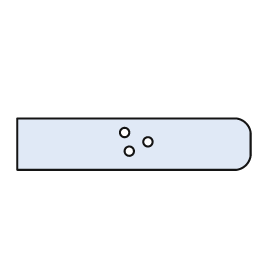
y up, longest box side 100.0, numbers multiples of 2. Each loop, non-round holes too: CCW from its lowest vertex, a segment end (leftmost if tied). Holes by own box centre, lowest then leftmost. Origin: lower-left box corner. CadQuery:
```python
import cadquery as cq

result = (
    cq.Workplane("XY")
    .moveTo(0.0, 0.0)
    .lineTo(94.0, 0.0)
    .threePointArc((98.0, 2.0), (100.0, 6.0))
    .lineTo(100.0, 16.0)
    .threePointArc((98.0, 20.0), (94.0, 22.0))
    .lineTo(0.0, 22.0)
    .close()
    .moveTo(48.0, 8.0)
    .circle(2.0)
    .moveTo(56.0, 12.0)
    .circle(2.0)
    .moveTo(46.0, 16.0)
    .circle(2.0)
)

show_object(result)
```